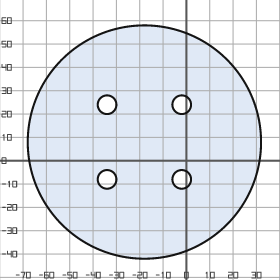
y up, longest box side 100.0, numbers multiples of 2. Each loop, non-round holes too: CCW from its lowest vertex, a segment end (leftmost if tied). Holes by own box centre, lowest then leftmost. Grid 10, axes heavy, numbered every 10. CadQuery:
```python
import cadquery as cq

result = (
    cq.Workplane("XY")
    .moveTo(-18.0, 8.0)
    .circle(50.0)
    .moveTo(-34.0, -8.0)
    .circle(4.0)
    .moveTo(-2.0, -8.0)
    .circle(4.0)
    .moveTo(-34.0, 24.0)
    .circle(4.0)
    .moveTo(-2.0, 24.0)
    .circle(4.0)
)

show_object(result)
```